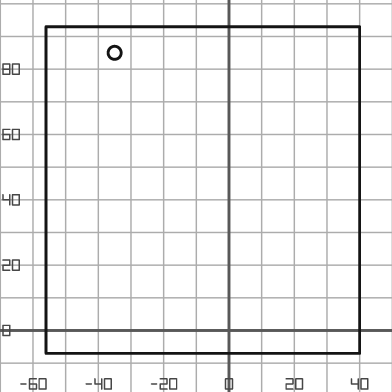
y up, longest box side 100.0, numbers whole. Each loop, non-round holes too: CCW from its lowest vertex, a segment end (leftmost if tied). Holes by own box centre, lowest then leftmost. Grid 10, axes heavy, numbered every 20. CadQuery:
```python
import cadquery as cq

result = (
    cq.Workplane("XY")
    .moveTo(-56.0, -7.0)
    .lineTo(40.0, -7.0)
    .lineTo(40.0, 93.0)
    .lineTo(-56.0, 93.0)
    .close()
    .moveTo(-35.0, 85.0)
    .circle(2.0)
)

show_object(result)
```